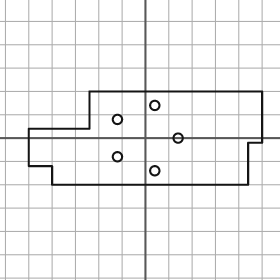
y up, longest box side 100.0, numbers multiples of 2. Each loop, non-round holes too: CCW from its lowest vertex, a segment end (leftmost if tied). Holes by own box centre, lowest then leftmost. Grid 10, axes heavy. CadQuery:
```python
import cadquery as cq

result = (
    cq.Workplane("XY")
    .moveTo(-40.0, -20.0)
    .lineTo(44.0, -20.0)
    .lineTo(44.0, -2.0)
    .lineTo(50.0, -2.0)
    .lineTo(50.0, 20.0)
    .lineTo(-24.0, 20.0)
    .lineTo(-24.0, 4.0)
    .lineTo(-50.0, 4.0)
    .lineTo(-50.0, -12.0)
    .lineTo(-40.0, -12.0)
    .close()
    .moveTo(4.0, -14.0)
    .circle(2.0)
    .moveTo(-12.0, -8.0)
    .circle(2.0)
    .moveTo(14.0, 0.0)
    .circle(2.0)
    .moveTo(-12.0, 8.0)
    .circle(2.0)
    .moveTo(4.0, 14.0)
    .circle(2.0)
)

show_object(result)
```